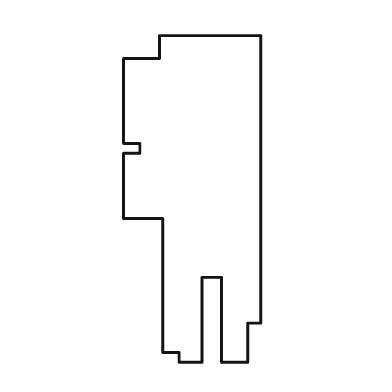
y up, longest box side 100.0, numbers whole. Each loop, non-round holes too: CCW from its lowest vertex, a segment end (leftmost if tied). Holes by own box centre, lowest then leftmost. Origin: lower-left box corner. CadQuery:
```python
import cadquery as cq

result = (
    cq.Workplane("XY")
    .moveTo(17.0, 0.0)
    .lineTo(24.0, 0.0)
    .lineTo(24.0, 26.0)
    .lineTo(30.0, 26.0)
    .lineTo(30.0, 0.0)
    .lineTo(38.0, 0.0)
    .lineTo(38.0, 12.0)
    .lineTo(42.0, 12.0)
    .lineTo(42.0, 100.0)
    .lineTo(11.0, 100.0)
    .lineTo(11.0, 93.0)
    .lineTo(0.0, 93.0)
    .lineTo(0.0, 67.0)
    .lineTo(5.0, 67.0)
    .lineTo(5.0, 64.0)
    .lineTo(0.0, 64.0)
    .lineTo(0.0, 44.0)
    .lineTo(12.0, 44.0)
    .lineTo(12.0, 3.0)
    .lineTo(17.0, 3.0)
    .close()
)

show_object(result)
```